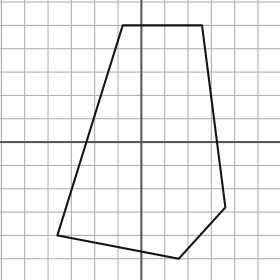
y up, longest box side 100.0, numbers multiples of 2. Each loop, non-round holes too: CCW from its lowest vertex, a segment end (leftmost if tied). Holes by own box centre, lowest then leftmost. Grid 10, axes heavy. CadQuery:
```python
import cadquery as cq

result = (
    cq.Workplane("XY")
    .moveTo(16.0, -50.0)
    .lineTo(36.0, -28.0)
    .lineTo(26.0, 50.0)
    .lineTo(-8.0, 50.0)
    .lineTo(-36.0, -40.0)
    .close()
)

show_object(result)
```